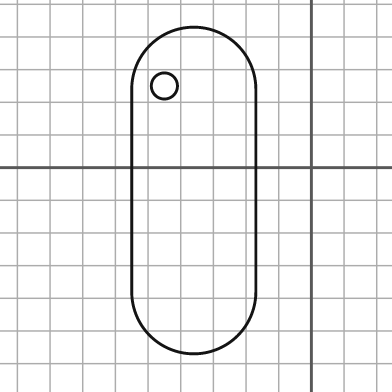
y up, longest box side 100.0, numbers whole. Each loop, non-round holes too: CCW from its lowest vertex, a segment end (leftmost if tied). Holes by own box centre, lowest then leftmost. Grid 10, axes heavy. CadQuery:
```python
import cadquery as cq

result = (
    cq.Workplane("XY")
    .moveTo(-55.0, -38.0)
    .threePointArc((-36.0, -57.0), (-17.0, -38.0))
    .lineTo(-17.0, 24.0)
    .threePointArc((-36.0, 43.0), (-55.0, 24.0))
    .close()
    .moveTo(-45.0, 25.0)
    .circle(4.0)
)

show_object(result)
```